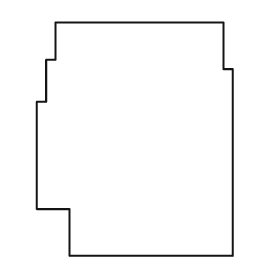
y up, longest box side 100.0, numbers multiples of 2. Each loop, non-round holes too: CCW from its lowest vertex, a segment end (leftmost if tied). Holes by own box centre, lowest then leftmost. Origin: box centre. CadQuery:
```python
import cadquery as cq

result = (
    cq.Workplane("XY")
    .moveTo(-28.0, -50.0)
    .lineTo(42.0, -50.0)
    .lineTo(42.0, 30.0)
    .lineTo(38.0, 30.0)
    .lineTo(38.0, 50.0)
    .lineTo(-34.0, 50.0)
    .lineTo(-34.0, 34.0)
    .lineTo(-38.0, 34.0)
    .lineTo(-38.0, 16.0)
    .lineTo(-42.0, 16.0)
    .lineTo(-42.0, -30.0)
    .lineTo(-28.0, -30.0)
    .close()
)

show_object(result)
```